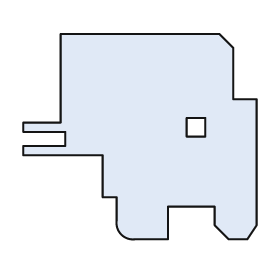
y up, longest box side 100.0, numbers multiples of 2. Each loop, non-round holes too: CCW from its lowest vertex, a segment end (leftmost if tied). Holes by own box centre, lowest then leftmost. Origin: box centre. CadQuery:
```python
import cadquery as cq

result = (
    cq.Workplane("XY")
    .moveTo(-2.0, -44.0)
    .lineTo(12.0, -44.0)
    .lineTo(12.0, -30.0)
    .lineTo(32.0, -30.0)
    .lineTo(32.0, -38.0)
    .lineTo(38.0, -44.0)
    .lineTo(46.0, -44.0)
    .lineTo(50.0, -38.0)
    .lineTo(50.0, 16.0)
    .lineTo(40.0, 16.0)
    .lineTo(40.0, 38.0)
    .lineTo(34.0, 44.0)
    .lineTo(-34.0, 44.0)
    .lineTo(-34.0, 6.0)
    .lineTo(-50.0, 6.0)
    .lineTo(-50.0, 2.0)
    .lineTo(-32.0, 2.0)
    .lineTo(-32.0, -4.0)
    .lineTo(-50.0, -4.0)
    .lineTo(-50.0, -8.0)
    .lineTo(-16.0, -8.0)
    .lineTo(-16.0, -26.0)
    .lineTo(-10.0, -26.0)
    .lineTo(-10.0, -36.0)
    .threePointArc((-8.0, -42.0), (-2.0, -44.0))
    .close()
    .moveTo(20.0, 0.0)
    .lineTo(28.0, 0.0)
    .lineTo(28.0, 8.0)
    .lineTo(20.0, 8.0)
    .close()
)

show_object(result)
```